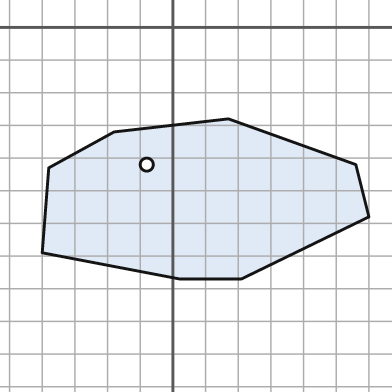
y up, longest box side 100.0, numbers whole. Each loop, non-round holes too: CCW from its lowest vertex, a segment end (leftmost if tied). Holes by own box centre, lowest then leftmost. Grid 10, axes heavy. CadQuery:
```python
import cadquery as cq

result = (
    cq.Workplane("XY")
    .moveTo(2.0, -77.0)
    .lineTo(21.0, -77.0)
    .lineTo(60.0, -58.0)
    .lineTo(56.0, -42.0)
    .lineTo(17.0, -28.0)
    .lineTo(-18.0, -32.0)
    .lineTo(-38.0, -43.0)
    .lineTo(-40.0, -69.0)
    .close()
    .moveTo(-8.0, -42.0)
    .circle(2.0)
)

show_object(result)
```